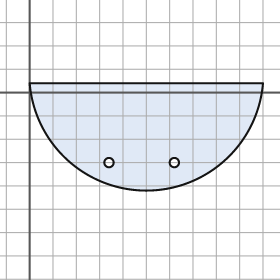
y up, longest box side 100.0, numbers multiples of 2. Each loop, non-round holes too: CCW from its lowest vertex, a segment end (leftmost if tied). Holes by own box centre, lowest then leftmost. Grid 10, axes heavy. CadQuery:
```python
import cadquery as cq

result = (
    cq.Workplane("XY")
    .moveTo(0.0, 4.0)
    .threePointArc((50.0, -42.0), (100.0, 4.0))
    .close()
    .moveTo(34.0, -30.0)
    .circle(2.0)
    .moveTo(62.0, -30.0)
    .circle(2.0)
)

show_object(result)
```